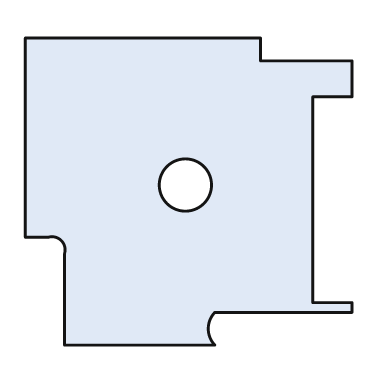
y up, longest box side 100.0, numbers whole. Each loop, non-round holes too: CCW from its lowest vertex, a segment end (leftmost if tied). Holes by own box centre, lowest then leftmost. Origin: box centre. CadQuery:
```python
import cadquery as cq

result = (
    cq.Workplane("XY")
    .moveTo(-38.0, -47.0)
    .lineTo(8.0, -47.0)
    .threePointArc((6.0, -42.0), (8.0, -37.0))
    .lineTo(50.0, -37.0)
    .lineTo(50.0, -34.0)
    .lineTo(38.0, -34.0)
    .lineTo(38.0, 29.0)
    .lineTo(50.0, 29.0)
    .lineTo(50.0, 40.0)
    .lineTo(22.0, 40.0)
    .lineTo(22.0, 47.0)
    .lineTo(-50.0, 47.0)
    .lineTo(-50.0, -14.0)
    .lineTo(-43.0, -14.0)
    .threePointArc((-39.0, -15.0), (-38.0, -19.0))
    .close()
    .moveTo(-1.0, 2.0)
    .circle(8.0)
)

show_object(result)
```